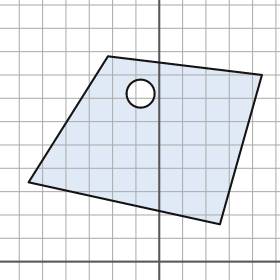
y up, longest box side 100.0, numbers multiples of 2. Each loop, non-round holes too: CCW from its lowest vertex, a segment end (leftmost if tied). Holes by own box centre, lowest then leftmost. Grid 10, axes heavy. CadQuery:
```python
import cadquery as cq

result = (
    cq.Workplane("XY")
    .moveTo(26.0, 16.0)
    .lineTo(44.0, 80.0)
    .lineTo(-22.0, 88.0)
    .lineTo(-56.0, 34.0)
    .close()
    .moveTo(-8.0, 72.0)
    .circle(6.0)
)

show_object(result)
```